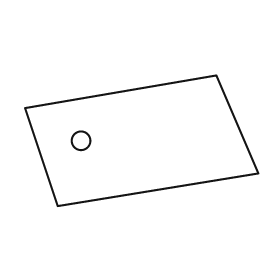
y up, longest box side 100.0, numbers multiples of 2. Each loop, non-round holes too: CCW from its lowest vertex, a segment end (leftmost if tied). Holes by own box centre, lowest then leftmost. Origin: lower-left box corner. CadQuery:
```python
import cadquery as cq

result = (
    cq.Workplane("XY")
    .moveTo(14.0, 0.0)
    .lineTo(100.0, 14.0)
    .lineTo(82.0, 56.0)
    .lineTo(0.0, 42.0)
    .close()
    .moveTo(24.0, 28.0)
    .circle(4.0)
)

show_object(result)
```